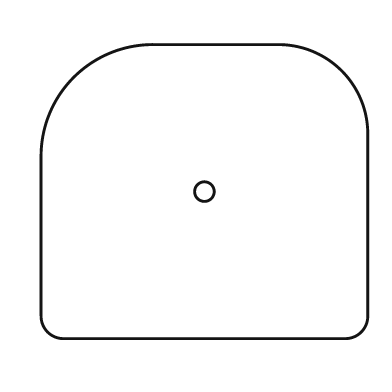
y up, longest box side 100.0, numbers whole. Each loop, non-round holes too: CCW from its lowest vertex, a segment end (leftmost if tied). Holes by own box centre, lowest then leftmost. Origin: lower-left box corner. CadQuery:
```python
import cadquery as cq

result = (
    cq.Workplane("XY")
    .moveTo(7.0, 0.0)
    .lineTo(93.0, 0.0)
    .threePointArc((98.0, 2.0), (100.0, 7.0))
    .lineTo(100.0, 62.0)
    .threePointArc((92.0, 82.0), (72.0, 90.0))
    .lineTo(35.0, 90.0)
    .threePointArc((10.0, 80.0), (0.0, 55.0))
    .lineTo(0.0, 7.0)
    .threePointArc((2.0, 2.0), (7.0, 0.0))
    .close()
    .moveTo(50.0, 45.0)
    .circle(3.0)
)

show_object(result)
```